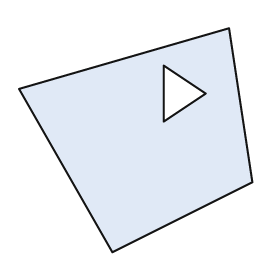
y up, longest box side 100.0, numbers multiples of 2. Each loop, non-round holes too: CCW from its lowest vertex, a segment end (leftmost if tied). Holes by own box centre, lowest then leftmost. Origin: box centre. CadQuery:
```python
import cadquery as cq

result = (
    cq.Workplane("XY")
    .moveTo(-10.0, -48.0)
    .lineTo(50.0, -18.0)
    .lineTo(40.0, 48.0)
    .lineTo(-50.0, 22.0)
    .close()
    .moveTo(12.0, 8.0)
    .lineTo(30.0, 20.0)
    .lineTo(12.0, 32.0)
    .close()
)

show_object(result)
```